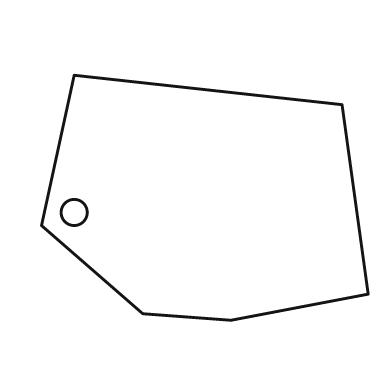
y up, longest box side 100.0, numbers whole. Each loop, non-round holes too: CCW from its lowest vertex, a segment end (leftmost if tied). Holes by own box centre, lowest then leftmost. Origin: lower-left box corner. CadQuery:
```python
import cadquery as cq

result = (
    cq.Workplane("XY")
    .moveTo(58.0, 0.0)
    .lineTo(100.0, 8.0)
    .lineTo(92.0, 66.0)
    .lineTo(10.0, 75.0)
    .lineTo(0.0, 29.0)
    .lineTo(31.0, 2.0)
    .close()
    .moveTo(10.0, 33.0)
    .circle(4.0)
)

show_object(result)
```